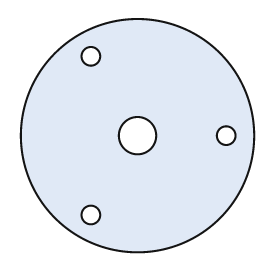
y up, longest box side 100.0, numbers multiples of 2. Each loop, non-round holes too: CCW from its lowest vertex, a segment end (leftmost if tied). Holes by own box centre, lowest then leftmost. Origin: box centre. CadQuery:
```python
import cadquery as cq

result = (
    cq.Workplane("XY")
    .moveTo(0.0, 0.0)
    .circle(50.0)
    .moveTo(-20.0, -34.0)
    .circle(4.0)
    .moveTo(0.0, 0.0)
    .circle(8.0)
    .moveTo(38.0, 0.0)
    .circle(4.0)
    .moveTo(-20.0, 34.0)
    .circle(4.0)
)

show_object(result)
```